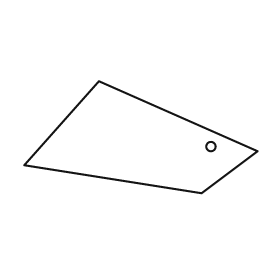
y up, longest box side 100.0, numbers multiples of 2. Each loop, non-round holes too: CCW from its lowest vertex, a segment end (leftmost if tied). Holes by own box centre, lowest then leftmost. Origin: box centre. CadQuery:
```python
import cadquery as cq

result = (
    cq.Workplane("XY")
    .moveTo(26.0, -24.0)
    .lineTo(50.0, -6.0)
    .lineTo(-18.0, 24.0)
    .lineTo(-50.0, -12.0)
    .close()
    .moveTo(30.0, -4.0)
    .circle(2.0)
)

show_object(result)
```